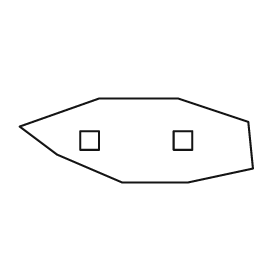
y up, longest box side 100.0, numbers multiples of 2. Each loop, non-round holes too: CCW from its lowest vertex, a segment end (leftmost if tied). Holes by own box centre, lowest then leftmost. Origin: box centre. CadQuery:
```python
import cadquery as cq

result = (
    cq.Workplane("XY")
    .moveTo(-6.0, -18.0)
    .lineTo(22.0, -18.0)
    .lineTo(50.0, -12.0)
    .lineTo(48.0, 8.0)
    .lineTo(18.0, 18.0)
    .lineTo(-16.0, 18.0)
    .lineTo(-50.0, 6.0)
    .lineTo(-34.0, -6.0)
    .close()
    .moveTo(-24.0, -4.0)
    .lineTo(-16.0, -4.0)
    .lineTo(-16.0, 4.0)
    .lineTo(-24.0, 4.0)
    .close()
    .moveTo(16.0, -4.0)
    .lineTo(24.0, -4.0)
    .lineTo(24.0, 4.0)
    .lineTo(16.0, 4.0)
    .close()
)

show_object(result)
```